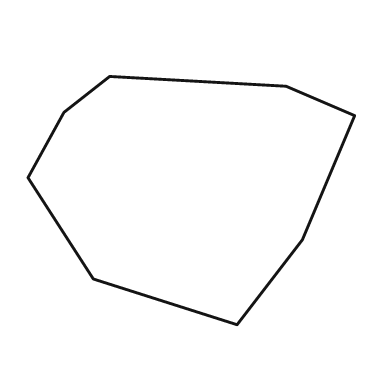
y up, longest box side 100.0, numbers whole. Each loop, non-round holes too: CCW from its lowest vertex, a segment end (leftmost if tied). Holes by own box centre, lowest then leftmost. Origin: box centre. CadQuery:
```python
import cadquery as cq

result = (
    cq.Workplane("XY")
    .moveTo(14.0, -38.0)
    .lineTo(34.0, -12.0)
    .lineTo(50.0, 26.0)
    .lineTo(29.0, 35.0)
    .lineTo(-25.0, 38.0)
    .lineTo(-39.0, 27.0)
    .lineTo(-50.0, 7.0)
    .lineTo(-30.0, -24.0)
    .close()
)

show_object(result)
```